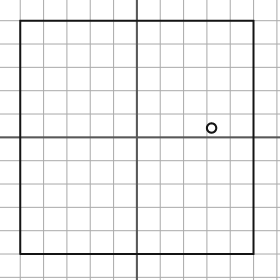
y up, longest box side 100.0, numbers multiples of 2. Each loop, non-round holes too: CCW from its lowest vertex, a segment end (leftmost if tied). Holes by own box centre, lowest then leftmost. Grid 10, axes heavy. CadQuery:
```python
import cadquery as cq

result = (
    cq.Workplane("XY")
    .moveTo(-50.0, -50.0)
    .lineTo(50.0, -50.0)
    .lineTo(50.0, 50.0)
    .lineTo(-50.0, 50.0)
    .close()
    .moveTo(32.0, 4.0)
    .circle(2.0)
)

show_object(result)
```